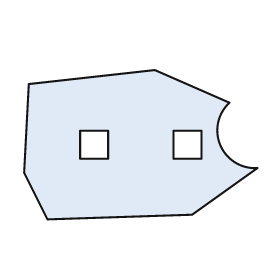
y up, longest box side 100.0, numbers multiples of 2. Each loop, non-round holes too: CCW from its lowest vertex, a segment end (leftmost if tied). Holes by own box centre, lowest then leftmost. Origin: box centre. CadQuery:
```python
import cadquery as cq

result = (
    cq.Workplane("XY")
    .moveTo(-40.0, -32.0)
    .lineTo(22.0, -30.0)
    .lineTo(50.0, -10.0)
    .threePointArc((34.0, 0.0), (38.0, 18.0))
    .lineTo(6.0, 32.0)
    .lineTo(-48.0, 26.0)
    .lineTo(-50.0, -12.0)
    .close()
    .moveTo(-26.0, -6.0)
    .lineTo(-14.0, -6.0)
    .lineTo(-14.0, 6.0)
    .lineTo(-26.0, 6.0)
    .close()
    .moveTo(14.0, -6.0)
    .lineTo(26.0, -6.0)
    .lineTo(26.0, 6.0)
    .lineTo(14.0, 6.0)
    .close()
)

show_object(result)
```